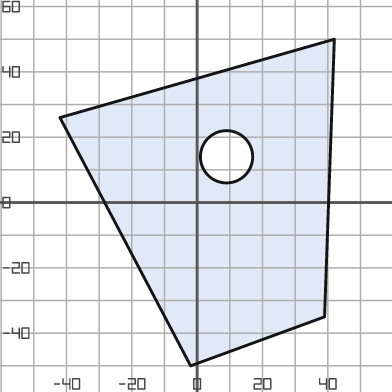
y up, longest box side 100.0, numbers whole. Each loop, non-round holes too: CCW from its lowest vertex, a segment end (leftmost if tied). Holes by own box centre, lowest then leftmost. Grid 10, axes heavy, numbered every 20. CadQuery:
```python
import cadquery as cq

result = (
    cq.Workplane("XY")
    .moveTo(-2.0, -50.0)
    .lineTo(39.0, -35.0)
    .lineTo(42.0, 50.0)
    .lineTo(-42.0, 26.0)
    .close()
    .moveTo(9.0, 14.0)
    .circle(8.0)
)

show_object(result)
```